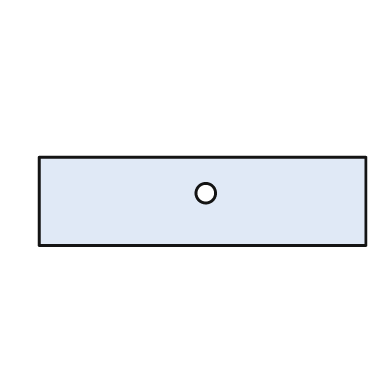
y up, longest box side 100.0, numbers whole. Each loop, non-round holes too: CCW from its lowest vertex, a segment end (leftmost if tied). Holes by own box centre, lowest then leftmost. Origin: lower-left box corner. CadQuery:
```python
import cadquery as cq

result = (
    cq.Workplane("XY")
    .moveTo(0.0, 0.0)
    .lineTo(100.0, 0.0)
    .lineTo(100.0, 27.0)
    .lineTo(0.0, 27.0)
    .close()
    .moveTo(51.0, 16.0)
    .circle(3.0)
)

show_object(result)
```